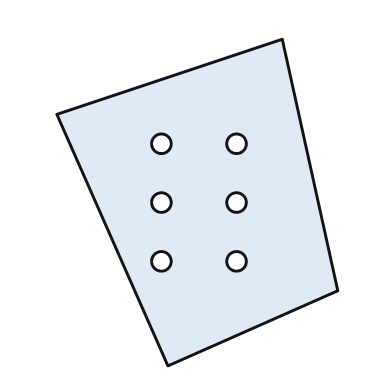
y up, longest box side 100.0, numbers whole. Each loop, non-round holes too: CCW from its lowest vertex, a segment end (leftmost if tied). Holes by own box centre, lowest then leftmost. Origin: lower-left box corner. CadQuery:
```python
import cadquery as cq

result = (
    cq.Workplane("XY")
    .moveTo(34.0, 0.0)
    .lineTo(86.0, 23.0)
    .lineTo(69.0, 100.0)
    .lineTo(0.0, 77.0)
    .close()
    .moveTo(32.0, 32.0)
    .circle(3.0)
    .moveTo(55.0, 32.0)
    .circle(3.0)
    .moveTo(32.0, 50.0)
    .circle(3.0)
    .moveTo(55.0, 50.0)
    .circle(3.0)
    .moveTo(32.0, 68.0)
    .circle(3.0)
    .moveTo(55.0, 68.0)
    .circle(3.0)
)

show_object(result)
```